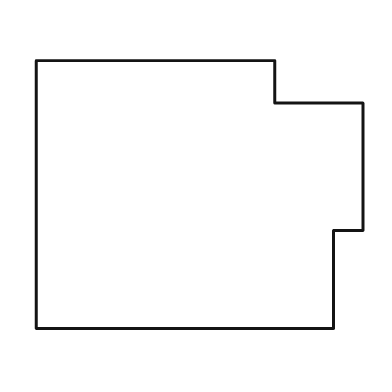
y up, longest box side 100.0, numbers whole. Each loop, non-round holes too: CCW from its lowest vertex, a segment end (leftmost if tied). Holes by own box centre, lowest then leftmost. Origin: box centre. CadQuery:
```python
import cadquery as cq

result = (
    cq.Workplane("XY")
    .moveTo(-50.0, -41.0)
    .lineTo(41.0, -41.0)
    .lineTo(41.0, -11.0)
    .lineTo(50.0, -11.0)
    .lineTo(50.0, 28.0)
    .lineTo(23.0, 28.0)
    .lineTo(23.0, 41.0)
    .lineTo(-50.0, 41.0)
    .close()
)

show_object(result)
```